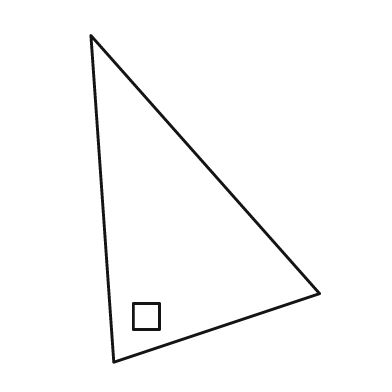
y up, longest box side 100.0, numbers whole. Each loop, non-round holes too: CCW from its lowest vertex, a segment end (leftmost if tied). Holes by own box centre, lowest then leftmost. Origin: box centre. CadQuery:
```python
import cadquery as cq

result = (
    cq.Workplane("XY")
    .moveTo(-28.0, -50.0)
    .lineTo(35.0, -29.0)
    .lineTo(-35.0, 50.0)
    .close()
    .moveTo(-22.0, -40.0)
    .lineTo(-14.0, -40.0)
    .lineTo(-14.0, -32.0)
    .lineTo(-22.0, -32.0)
    .close()
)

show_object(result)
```